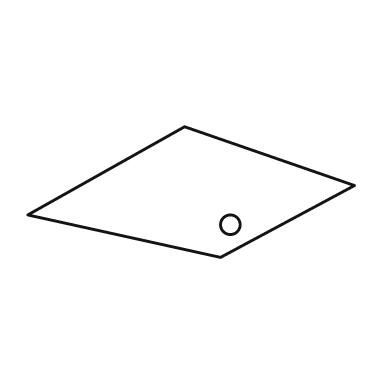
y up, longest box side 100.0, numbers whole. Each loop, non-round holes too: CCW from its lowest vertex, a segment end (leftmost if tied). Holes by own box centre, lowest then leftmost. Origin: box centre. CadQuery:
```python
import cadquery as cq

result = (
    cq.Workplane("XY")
    .moveTo(9.0, -20.0)
    .lineTo(50.0, 2.0)
    .lineTo(-2.0, 20.0)
    .lineTo(-50.0, -7.0)
    .close()
    .moveTo(12.0, -10.0)
    .circle(3.0)
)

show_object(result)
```